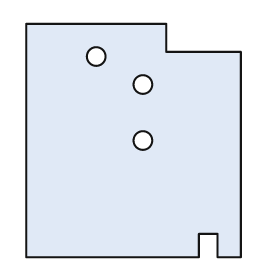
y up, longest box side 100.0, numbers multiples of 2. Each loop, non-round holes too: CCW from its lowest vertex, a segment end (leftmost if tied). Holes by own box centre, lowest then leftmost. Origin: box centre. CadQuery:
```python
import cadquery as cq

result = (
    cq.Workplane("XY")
    .moveTo(-46.0, -50.0)
    .lineTo(28.0, -50.0)
    .lineTo(28.0, -40.0)
    .lineTo(36.0, -40.0)
    .lineTo(36.0, -50.0)
    .lineTo(46.0, -50.0)
    .lineTo(46.0, 38.0)
    .lineTo(14.0, 38.0)
    .lineTo(14.0, 50.0)
    .lineTo(-46.0, 50.0)
    .close()
    .moveTo(4.0, 0.0)
    .circle(4.0)
    .moveTo(4.0, 24.0)
    .circle(4.0)
    .moveTo(-16.0, 36.0)
    .circle(4.0)
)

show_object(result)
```